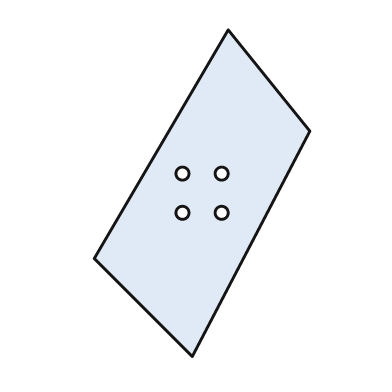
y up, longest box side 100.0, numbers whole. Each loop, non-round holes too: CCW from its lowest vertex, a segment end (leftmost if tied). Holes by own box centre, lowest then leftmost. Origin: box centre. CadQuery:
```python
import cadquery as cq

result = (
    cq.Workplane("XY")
    .moveTo(-3.0, -50.0)
    .lineTo(33.0, 19.0)
    .lineTo(8.0, 50.0)
    .lineTo(-33.0, -20.0)
    .close()
    .moveTo(-6.0, -6.0)
    .circle(2.0)
    .moveTo(6.0, -6.0)
    .circle(2.0)
    .moveTo(-6.0, 6.0)
    .circle(2.0)
    .moveTo(6.0, 6.0)
    .circle(2.0)
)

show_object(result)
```